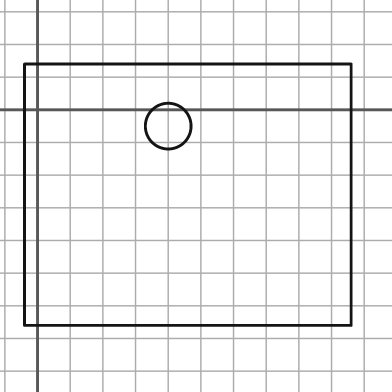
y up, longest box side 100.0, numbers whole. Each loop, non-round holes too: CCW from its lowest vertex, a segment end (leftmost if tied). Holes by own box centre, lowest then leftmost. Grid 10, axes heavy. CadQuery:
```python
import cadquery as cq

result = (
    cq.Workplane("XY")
    .moveTo(-4.0, -66.0)
    .lineTo(96.0, -66.0)
    .lineTo(96.0, 14.0)
    .lineTo(-4.0, 14.0)
    .close()
    .moveTo(40.0, -5.0)
    .circle(7.0)
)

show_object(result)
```